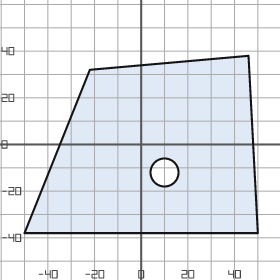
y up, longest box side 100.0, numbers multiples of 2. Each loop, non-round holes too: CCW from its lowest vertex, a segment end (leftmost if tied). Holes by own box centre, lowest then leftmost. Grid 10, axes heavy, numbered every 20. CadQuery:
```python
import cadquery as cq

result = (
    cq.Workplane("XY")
    .moveTo(-50.0, -38.0)
    .lineTo(50.0, -38.0)
    .lineTo(46.0, 38.0)
    .lineTo(-22.0, 32.0)
    .close()
    .moveTo(10.0, -12.0)
    .circle(6.0)
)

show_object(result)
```